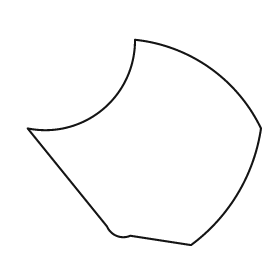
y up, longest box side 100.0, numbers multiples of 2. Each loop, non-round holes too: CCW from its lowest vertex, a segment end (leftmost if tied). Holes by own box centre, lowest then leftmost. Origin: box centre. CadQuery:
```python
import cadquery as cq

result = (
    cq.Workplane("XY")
    .moveTo(20.0, -44.0)
    .threePointArc((40.0, -22.0), (50.0, 6.0))
    .threePointArc((28.0, 32.0), (-4.0, 44.0))
    .threePointArc((-18.0, 14.0), (-50.0, 6.0))
    .lineTo(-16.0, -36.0)
    .threePointArc((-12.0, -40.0), (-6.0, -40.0))
    .close()
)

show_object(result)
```